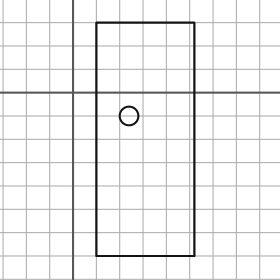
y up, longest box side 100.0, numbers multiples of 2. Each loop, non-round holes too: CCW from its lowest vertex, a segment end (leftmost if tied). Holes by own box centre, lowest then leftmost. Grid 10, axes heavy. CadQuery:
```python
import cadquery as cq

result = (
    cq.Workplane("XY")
    .moveTo(10.0, -70.0)
    .lineTo(52.0, -70.0)
    .lineTo(52.0, 30.0)
    .lineTo(10.0, 30.0)
    .close()
    .moveTo(24.0, -10.0)
    .circle(4.0)
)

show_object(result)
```